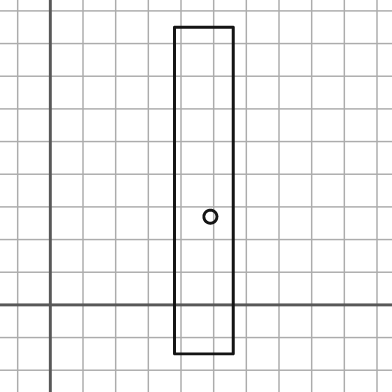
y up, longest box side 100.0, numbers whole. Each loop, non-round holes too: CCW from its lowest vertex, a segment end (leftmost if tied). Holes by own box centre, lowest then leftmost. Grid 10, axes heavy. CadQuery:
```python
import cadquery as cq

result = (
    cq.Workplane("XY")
    .moveTo(38.0, -15.0)
    .lineTo(56.0, -15.0)
    .lineTo(56.0, 85.0)
    .lineTo(38.0, 85.0)
    .close()
    .moveTo(49.0, 27.0)
    .circle(2.0)
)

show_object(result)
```